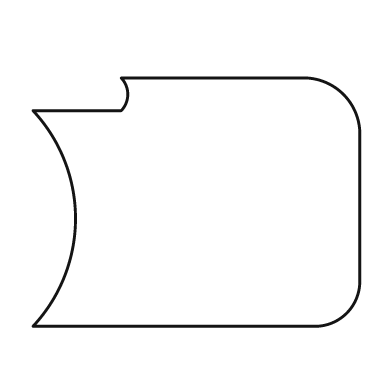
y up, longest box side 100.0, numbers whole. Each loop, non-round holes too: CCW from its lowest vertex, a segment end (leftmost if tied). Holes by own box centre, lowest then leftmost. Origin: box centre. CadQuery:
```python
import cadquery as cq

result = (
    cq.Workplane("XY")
    .moveTo(-50.0, -38.0)
    .lineTo(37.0, -38.0)
    .threePointArc((46.0, -34.0), (50.0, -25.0))
    .lineTo(50.0, 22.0)
    .threePointArc((45.0, 33.0), (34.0, 38.0))
    .lineTo(-23.0, 38.0)
    .threePointArc((-21.0, 33.0), (-23.0, 28.0))
    .lineTo(-50.0, 28.0)
    .threePointArc((-37.0, -5.0), (-50.0, -38.0))
    .close()
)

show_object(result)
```